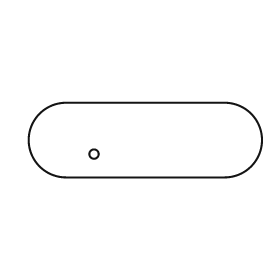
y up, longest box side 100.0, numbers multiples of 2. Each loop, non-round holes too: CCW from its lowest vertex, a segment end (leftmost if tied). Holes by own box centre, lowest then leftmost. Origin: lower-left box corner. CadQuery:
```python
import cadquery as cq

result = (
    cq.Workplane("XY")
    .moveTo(16.0, 0.0)
    .lineTo(84.0, 0.0)
    .threePointArc((100.0, 16.0), (84.0, 32.0))
    .lineTo(16.0, 32.0)
    .threePointArc((0.0, 16.0), (16.0, 0.0))
    .close()
    .moveTo(28.0, 10.0)
    .circle(2.0)
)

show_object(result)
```